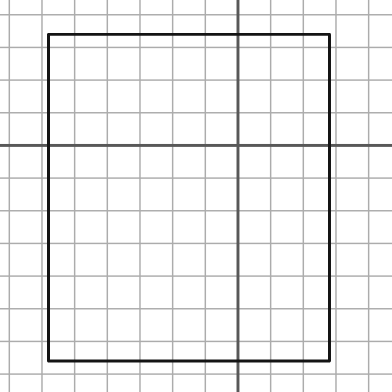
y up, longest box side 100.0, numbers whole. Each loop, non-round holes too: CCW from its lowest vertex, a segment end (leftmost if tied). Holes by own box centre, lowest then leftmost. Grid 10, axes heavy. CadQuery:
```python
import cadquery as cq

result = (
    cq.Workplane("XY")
    .moveTo(-58.0, -66.0)
    .lineTo(28.0, -66.0)
    .lineTo(28.0, 34.0)
    .lineTo(-58.0, 34.0)
    .close()
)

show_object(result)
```